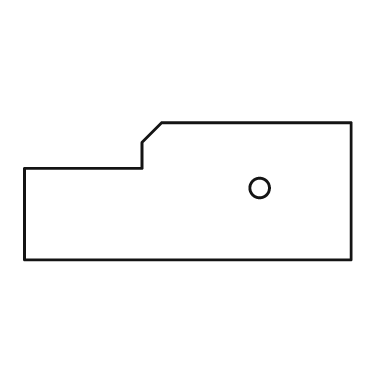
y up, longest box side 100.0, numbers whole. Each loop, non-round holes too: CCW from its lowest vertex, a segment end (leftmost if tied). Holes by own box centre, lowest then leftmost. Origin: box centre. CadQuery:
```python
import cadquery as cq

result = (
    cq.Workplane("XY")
    .moveTo(-50.0, -21.0)
    .lineTo(50.0, -21.0)
    .lineTo(50.0, 21.0)
    .lineTo(-8.0, 21.0)
    .lineTo(-14.0, 15.0)
    .lineTo(-14.0, 7.0)
    .lineTo(-50.0, 7.0)
    .close()
    .moveTo(22.0, 1.0)
    .circle(3.0)
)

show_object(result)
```